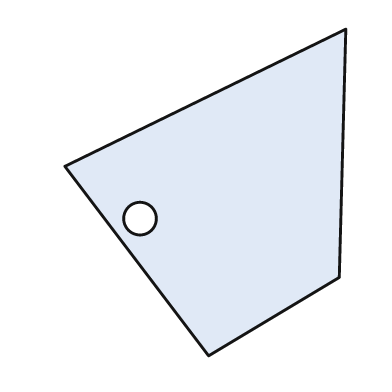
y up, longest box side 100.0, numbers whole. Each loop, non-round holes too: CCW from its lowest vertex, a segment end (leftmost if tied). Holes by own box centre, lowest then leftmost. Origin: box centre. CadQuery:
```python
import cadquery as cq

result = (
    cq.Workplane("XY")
    .moveTo(1.0, -50.0)
    .lineTo(41.0, -26.0)
    .lineTo(43.0, 50.0)
    .lineTo(-43.0, 8.0)
    .close()
    .moveTo(-20.0, -8.0)
    .circle(5.0)
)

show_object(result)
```